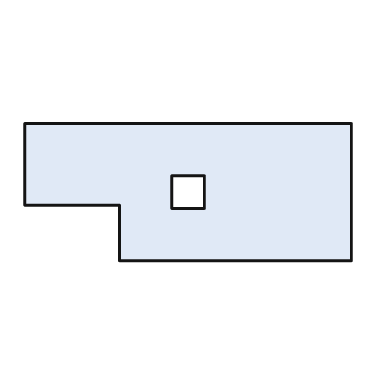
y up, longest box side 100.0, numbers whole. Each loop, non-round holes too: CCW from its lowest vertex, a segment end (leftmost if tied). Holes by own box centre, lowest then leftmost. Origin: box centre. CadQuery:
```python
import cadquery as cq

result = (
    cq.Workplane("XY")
    .moveTo(-21.0, -21.0)
    .lineTo(50.0, -21.0)
    .lineTo(50.0, 21.0)
    .lineTo(-50.0, 21.0)
    .lineTo(-50.0, -4.0)
    .lineTo(-21.0, -4.0)
    .close()
    .moveTo(-5.0, -5.0)
    .lineTo(5.0, -5.0)
    .lineTo(5.0, 5.0)
    .lineTo(-5.0, 5.0)
    .close()
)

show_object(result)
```